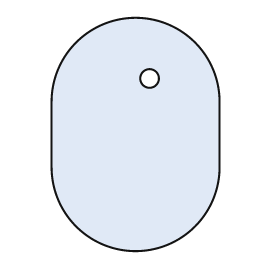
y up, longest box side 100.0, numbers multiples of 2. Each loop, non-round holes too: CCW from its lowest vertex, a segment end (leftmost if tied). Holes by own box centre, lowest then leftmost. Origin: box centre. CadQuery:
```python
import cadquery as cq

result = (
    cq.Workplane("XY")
    .moveTo(-36.0, -14.0)
    .threePointArc((0.0, -50.0), (36.0, -14.0))
    .lineTo(36.0, 14.0)
    .threePointArc((0.0, 50.0), (-36.0, 14.0))
    .close()
    .moveTo(6.0, 24.0)
    .circle(4.0)
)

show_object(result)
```